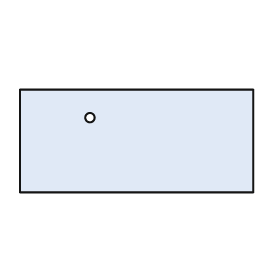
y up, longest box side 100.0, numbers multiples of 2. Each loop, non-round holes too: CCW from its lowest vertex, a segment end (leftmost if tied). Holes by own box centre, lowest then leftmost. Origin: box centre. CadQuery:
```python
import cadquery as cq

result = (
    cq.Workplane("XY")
    .moveTo(-50.0, -22.0)
    .lineTo(50.0, -22.0)
    .lineTo(50.0, 22.0)
    .lineTo(-50.0, 22.0)
    .close()
    .moveTo(-20.0, 10.0)
    .circle(2.0)
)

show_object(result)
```